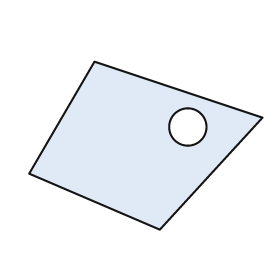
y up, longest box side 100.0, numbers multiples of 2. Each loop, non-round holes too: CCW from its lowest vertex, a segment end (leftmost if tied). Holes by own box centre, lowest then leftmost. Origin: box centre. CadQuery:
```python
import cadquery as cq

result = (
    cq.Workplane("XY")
    .moveTo(6.0, -36.0)
    .lineTo(50.0, 12.0)
    .lineTo(-22.0, 36.0)
    .lineTo(-50.0, -12.0)
    .close()
    .moveTo(18.0, 8.0)
    .circle(8.0)
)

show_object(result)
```